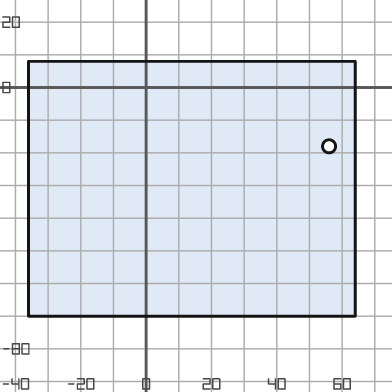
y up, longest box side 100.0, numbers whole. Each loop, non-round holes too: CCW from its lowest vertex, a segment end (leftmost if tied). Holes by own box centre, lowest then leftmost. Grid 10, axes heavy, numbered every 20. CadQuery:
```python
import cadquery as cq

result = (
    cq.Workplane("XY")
    .moveTo(-36.0, -70.0)
    .lineTo(64.0, -70.0)
    .lineTo(64.0, 8.0)
    .lineTo(-36.0, 8.0)
    .close()
    .moveTo(56.0, -18.0)
    .circle(2.0)
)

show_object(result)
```